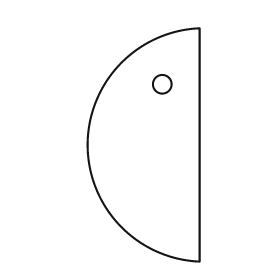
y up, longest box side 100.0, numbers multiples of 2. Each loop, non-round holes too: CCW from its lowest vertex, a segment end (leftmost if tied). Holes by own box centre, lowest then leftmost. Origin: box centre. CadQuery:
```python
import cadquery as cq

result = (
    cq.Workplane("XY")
    .moveTo(24.0, -50.0)
    .lineTo(24.0, 50.0)
    .threePointArc((-24.0, 0.0), (24.0, -50.0))
    .close()
    .moveTo(8.0, 26.0)
    .circle(4.0)
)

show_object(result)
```